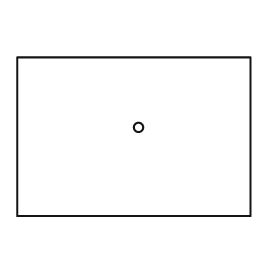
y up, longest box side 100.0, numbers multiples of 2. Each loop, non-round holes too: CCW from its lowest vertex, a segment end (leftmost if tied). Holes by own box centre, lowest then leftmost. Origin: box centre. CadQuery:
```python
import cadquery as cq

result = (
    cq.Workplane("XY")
    .moveTo(-50.0, -34.0)
    .lineTo(50.0, -34.0)
    .lineTo(50.0, 34.0)
    .lineTo(-50.0, 34.0)
    .close()
    .moveTo(2.0, 4.0)
    .circle(2.0)
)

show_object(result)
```